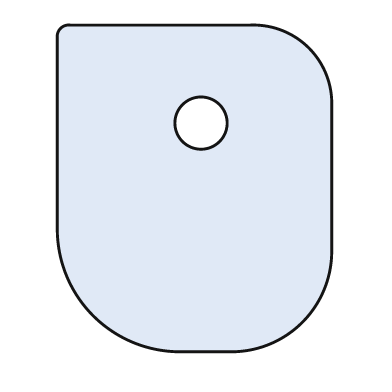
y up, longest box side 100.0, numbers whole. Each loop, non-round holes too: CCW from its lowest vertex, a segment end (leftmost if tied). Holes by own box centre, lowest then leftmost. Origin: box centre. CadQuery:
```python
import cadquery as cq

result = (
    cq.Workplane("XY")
    .moveTo(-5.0, -50.0)
    .lineTo(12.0, -50.0)
    .threePointArc((33.0, -41.0), (42.0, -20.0))
    .lineTo(42.0, 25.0)
    .threePointArc((35.0, 43.0), (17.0, 50.0))
    .lineTo(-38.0, 50.0)
    .threePointArc((-41.0, 49.0), (-42.0, 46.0))
    .lineTo(-42.0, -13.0)
    .threePointArc((-31.0, -39.0), (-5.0, -50.0))
    .close()
    .moveTo(2.0, 20.0)
    .circle(8.0)
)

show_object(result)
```